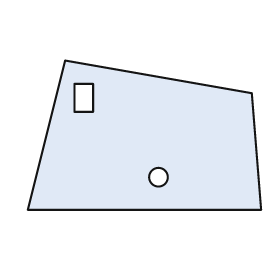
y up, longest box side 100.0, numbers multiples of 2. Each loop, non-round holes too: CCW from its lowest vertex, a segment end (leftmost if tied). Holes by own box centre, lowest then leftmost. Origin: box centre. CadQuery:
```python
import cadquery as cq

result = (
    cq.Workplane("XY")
    .moveTo(-50.0, -32.0)
    .lineTo(50.0, -32.0)
    .lineTo(46.0, 18.0)
    .lineTo(-34.0, 32.0)
    .close()
    .moveTo(6.0, -18.0)
    .circle(4.0)
    .moveTo(-30.0, 10.0)
    .lineTo(-22.0, 10.0)
    .lineTo(-22.0, 22.0)
    .lineTo(-30.0, 22.0)
    .close()
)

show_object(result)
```